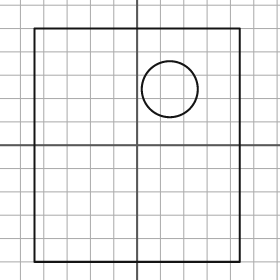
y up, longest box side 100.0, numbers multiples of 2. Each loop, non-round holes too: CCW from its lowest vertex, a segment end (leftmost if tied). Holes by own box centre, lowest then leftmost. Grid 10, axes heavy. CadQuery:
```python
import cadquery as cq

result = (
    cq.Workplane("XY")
    .moveTo(-44.0, -50.0)
    .lineTo(44.0, -50.0)
    .lineTo(44.0, 50.0)
    .lineTo(-44.0, 50.0)
    .close()
    .moveTo(14.0, 24.0)
    .circle(12.0)
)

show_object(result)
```